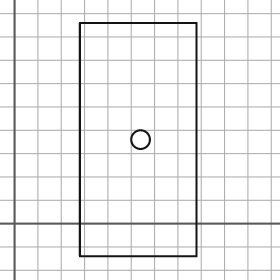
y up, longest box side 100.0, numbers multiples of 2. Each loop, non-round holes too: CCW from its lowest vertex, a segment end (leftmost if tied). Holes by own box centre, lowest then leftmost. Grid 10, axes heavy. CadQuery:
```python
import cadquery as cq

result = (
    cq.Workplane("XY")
    .moveTo(28.0, -14.0)
    .lineTo(78.0, -14.0)
    .lineTo(78.0, 86.0)
    .lineTo(28.0, 86.0)
    .close()
    .moveTo(54.0, 36.0)
    .circle(4.0)
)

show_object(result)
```